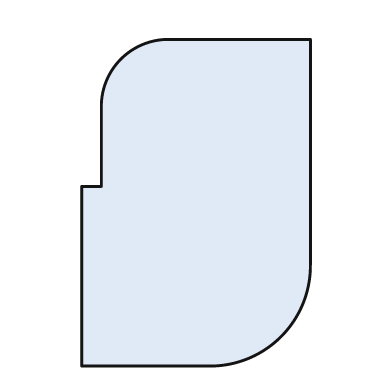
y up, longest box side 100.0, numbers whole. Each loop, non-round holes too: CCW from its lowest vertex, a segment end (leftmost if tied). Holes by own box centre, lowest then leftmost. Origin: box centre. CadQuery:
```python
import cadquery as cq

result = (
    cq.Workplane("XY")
    .moveTo(-35.0, -50.0)
    .lineTo(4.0, -50.0)
    .threePointArc((26.0, -41.0), (35.0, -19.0))
    .lineTo(35.0, 50.0)
    .lineTo(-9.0, 50.0)
    .threePointArc((-23.0, 44.0), (-29.0, 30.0))
    .lineTo(-29.0, 5.0)
    .lineTo(-35.0, 5.0)
    .close()
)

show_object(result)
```